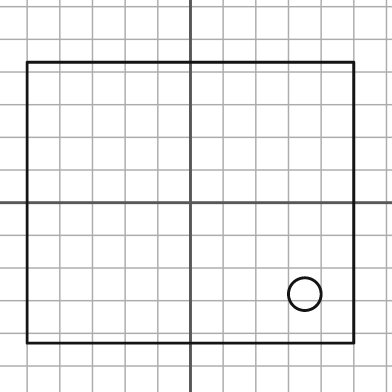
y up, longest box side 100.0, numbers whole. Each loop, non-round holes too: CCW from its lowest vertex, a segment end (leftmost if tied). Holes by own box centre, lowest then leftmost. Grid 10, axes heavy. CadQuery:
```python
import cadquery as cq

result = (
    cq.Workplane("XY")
    .moveTo(-50.0, -43.0)
    .lineTo(50.0, -43.0)
    .lineTo(50.0, 43.0)
    .lineTo(-50.0, 43.0)
    .close()
    .moveTo(35.0, -28.0)
    .circle(5.0)
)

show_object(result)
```